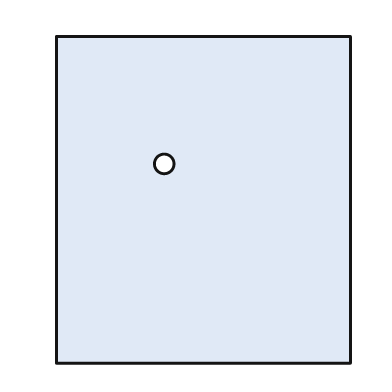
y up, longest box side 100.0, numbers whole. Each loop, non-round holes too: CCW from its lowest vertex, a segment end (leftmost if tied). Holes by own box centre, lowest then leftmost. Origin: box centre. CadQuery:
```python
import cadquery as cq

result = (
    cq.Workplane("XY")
    .moveTo(-45.0, -50.0)
    .lineTo(45.0, -50.0)
    .lineTo(45.0, 50.0)
    .lineTo(-45.0, 50.0)
    .close()
    .moveTo(-12.0, 11.0)
    .circle(3.0)
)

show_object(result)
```